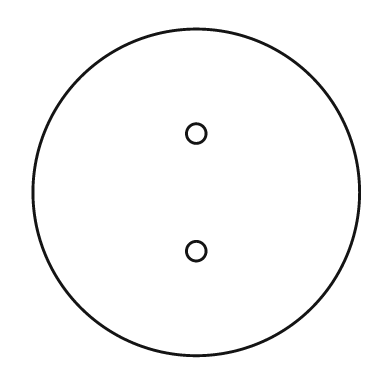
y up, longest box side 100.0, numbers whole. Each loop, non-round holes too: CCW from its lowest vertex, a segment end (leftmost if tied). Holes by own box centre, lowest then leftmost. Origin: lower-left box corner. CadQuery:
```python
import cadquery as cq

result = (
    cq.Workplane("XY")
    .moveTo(50.0, 50.0)
    .circle(50.0)
    .moveTo(50.0, 32.0)
    .circle(3.0)
    .moveTo(50.0, 68.0)
    .circle(3.0)
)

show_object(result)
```